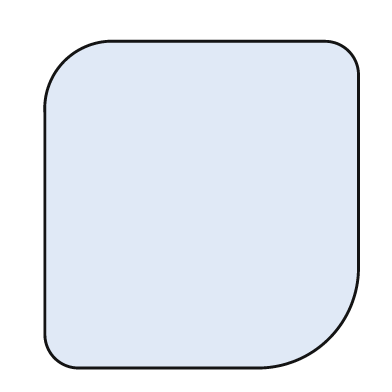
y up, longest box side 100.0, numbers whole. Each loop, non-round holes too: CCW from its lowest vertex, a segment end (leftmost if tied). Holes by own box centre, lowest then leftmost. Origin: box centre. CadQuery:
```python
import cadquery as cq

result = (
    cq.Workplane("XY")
    .moveTo(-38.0, -50.0)
    .lineTo(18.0, -50.0)
    .threePointArc((39.0, -41.0), (48.0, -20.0))
    .lineTo(48.0, 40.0)
    .threePointArc((45.0, 47.0), (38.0, 50.0))
    .lineTo(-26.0, 50.0)
    .threePointArc((-42.0, 44.0), (-48.0, 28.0))
    .lineTo(-48.0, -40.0)
    .threePointArc((-45.0, -47.0), (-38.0, -50.0))
    .close()
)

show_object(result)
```